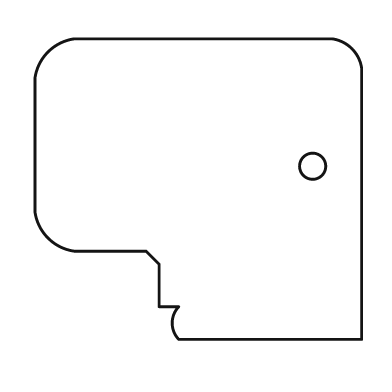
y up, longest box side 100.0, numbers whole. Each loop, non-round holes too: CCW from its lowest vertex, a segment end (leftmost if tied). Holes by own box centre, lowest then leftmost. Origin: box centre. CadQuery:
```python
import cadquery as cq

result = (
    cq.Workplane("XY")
    .moveTo(-6.0, -46.0)
    .lineTo(50.0, -46.0)
    .lineTo(50.0, 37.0)
    .threePointArc((47.0, 43.0), (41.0, 46.0))
    .lineTo(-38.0, 46.0)
    .threePointArc((-46.0, 42.0), (-50.0, 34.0))
    .lineTo(-50.0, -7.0)
    .threePointArc((-46.0, -15.0), (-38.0, -19.0))
    .lineTo(-16.0, -19.0)
    .lineTo(-12.0, -23.0)
    .lineTo(-12.0, -36.0)
    .lineTo(-6.0, -36.0)
    .threePointArc((-8.0, -41.0), (-6.0, -46.0))
    .close()
    .moveTo(35.0, 7.0)
    .circle(4.0)
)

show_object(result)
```